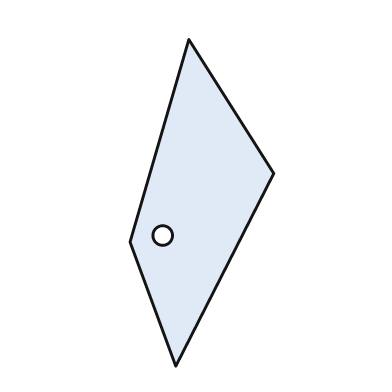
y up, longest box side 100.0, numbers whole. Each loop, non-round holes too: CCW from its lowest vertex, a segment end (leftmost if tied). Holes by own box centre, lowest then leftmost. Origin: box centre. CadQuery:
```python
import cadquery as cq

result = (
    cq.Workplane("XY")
    .moveTo(-8.0, -50.0)
    .lineTo(22.0, 9.0)
    .lineTo(-4.0, 50.0)
    .lineTo(-22.0, -12.0)
    .close()
    .moveTo(-12.0, -10.0)
    .circle(3.0)
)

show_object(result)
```